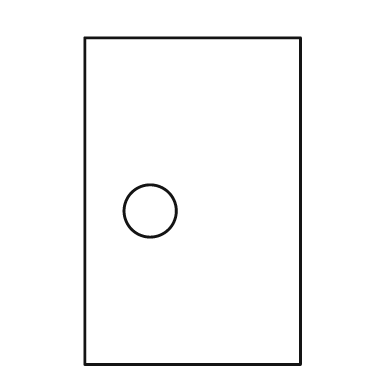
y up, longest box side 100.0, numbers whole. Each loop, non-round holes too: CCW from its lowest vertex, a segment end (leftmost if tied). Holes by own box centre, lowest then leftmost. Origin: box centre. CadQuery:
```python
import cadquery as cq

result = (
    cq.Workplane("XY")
    .moveTo(-33.0, -50.0)
    .lineTo(33.0, -50.0)
    .lineTo(33.0, 50.0)
    .lineTo(-33.0, 50.0)
    .close()
    .moveTo(-13.0, -3.0)
    .circle(8.0)
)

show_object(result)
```